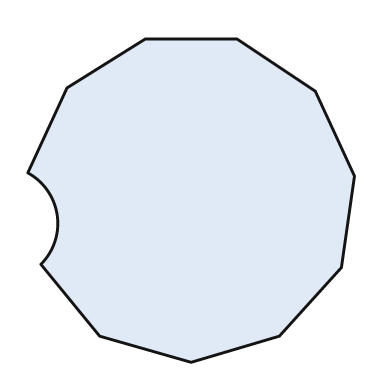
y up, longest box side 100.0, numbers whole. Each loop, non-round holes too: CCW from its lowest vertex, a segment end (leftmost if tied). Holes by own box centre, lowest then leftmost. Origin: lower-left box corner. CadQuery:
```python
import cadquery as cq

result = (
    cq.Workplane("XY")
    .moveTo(50.0, 0.0)
    .lineTo(77.0, 8.0)
    .lineTo(96.0, 29.0)
    .lineTo(100.0, 57.0)
    .lineTo(88.0, 83.0)
    .lineTo(64.0, 99.0)
    .lineTo(36.0, 99.0)
    .lineTo(12.0, 84.0)
    .lineTo(0.0, 58.0)
    .threePointArc((9.0, 45.0), (4.0, 30.0))
    .lineTo(22.0, 8.0)
    .close()
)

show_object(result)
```